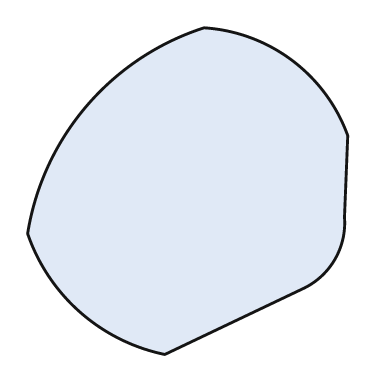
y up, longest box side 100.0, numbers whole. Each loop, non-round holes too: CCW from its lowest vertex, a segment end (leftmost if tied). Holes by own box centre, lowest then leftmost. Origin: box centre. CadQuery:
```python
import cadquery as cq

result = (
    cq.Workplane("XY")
    .moveTo(-7.0, -50.0)
    .lineTo(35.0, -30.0)
    .threePointArc((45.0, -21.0), (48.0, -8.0))
    .lineTo(49.0, 17.0)
    .threePointArc((32.0, 40.0), (5.0, 50.0))
    .threePointArc((-31.0, 26.0), (-49.0, -13.0))
    .threePointArc((-33.0, -37.0), (-7.0, -50.0))
    .close()
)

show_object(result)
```